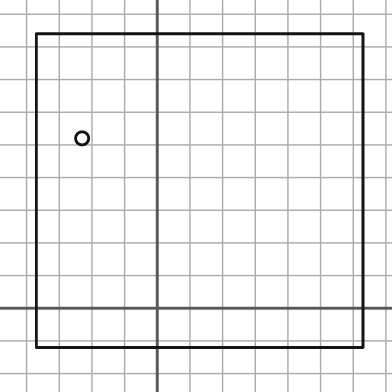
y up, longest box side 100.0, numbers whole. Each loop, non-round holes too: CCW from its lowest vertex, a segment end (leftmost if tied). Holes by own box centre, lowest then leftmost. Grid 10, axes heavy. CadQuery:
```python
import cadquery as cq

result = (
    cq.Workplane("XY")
    .moveTo(-37.0, -12.0)
    .lineTo(63.0, -12.0)
    .lineTo(63.0, 84.0)
    .lineTo(-37.0, 84.0)
    .close()
    .moveTo(-23.0, 52.0)
    .circle(2.0)
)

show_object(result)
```